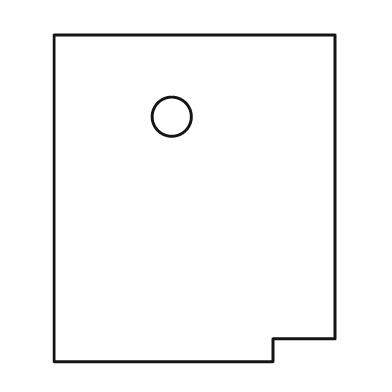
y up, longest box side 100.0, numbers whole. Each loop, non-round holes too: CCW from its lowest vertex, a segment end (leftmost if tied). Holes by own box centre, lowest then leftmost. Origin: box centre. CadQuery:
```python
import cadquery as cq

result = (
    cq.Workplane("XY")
    .moveTo(-43.0, -50.0)
    .lineTo(24.0, -50.0)
    .lineTo(24.0, -43.0)
    .lineTo(43.0, -43.0)
    .lineTo(43.0, 50.0)
    .lineTo(-43.0, 50.0)
    .close()
    .moveTo(-7.0, 25.0)
    .circle(6.0)
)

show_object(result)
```